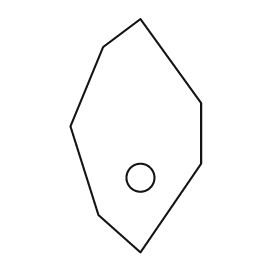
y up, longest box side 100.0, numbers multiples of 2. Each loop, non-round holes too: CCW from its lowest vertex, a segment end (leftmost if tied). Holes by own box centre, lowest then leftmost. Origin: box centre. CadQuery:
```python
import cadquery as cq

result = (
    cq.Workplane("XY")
    .moveTo(2.0, -50.0)
    .lineTo(28.0, -12.0)
    .lineTo(28.0, 14.0)
    .lineTo(2.0, 50.0)
    .lineTo(-14.0, 38.0)
    .lineTo(-28.0, 4.0)
    .lineTo(-16.0, -34.0)
    .close()
    .moveTo(2.0, -18.0)
    .circle(6.0)
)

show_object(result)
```